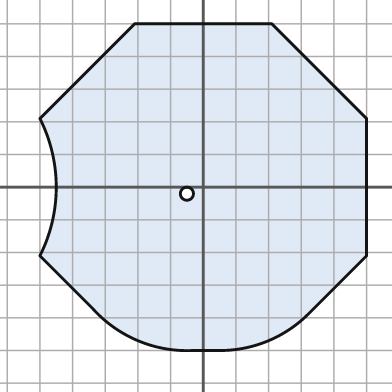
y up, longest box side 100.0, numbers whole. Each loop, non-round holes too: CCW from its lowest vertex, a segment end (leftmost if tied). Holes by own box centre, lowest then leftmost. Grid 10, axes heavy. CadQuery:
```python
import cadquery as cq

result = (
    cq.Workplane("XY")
    .moveTo(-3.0, -50.0)
    .lineTo(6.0, -50.0)
    .threePointArc((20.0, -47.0), (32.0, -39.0))
    .lineTo(50.0, -21.0)
    .lineTo(50.0, 21.0)
    .lineTo(21.0, 50.0)
    .lineTo(-21.0, 50.0)
    .lineTo(-50.0, 21.0)
    .threePointArc((-45.0, 0.0), (-50.0, -21.0))
    .lineTo(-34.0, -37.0)
    .threePointArc((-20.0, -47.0), (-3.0, -50.0))
    .close()
    .moveTo(-5.0, -2.0)
    .circle(2.0)
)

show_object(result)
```